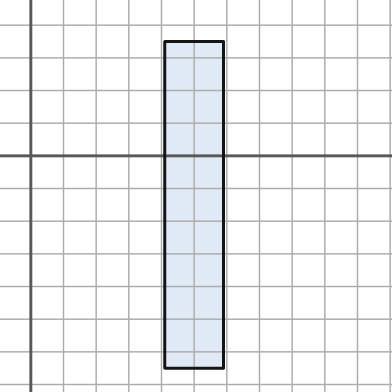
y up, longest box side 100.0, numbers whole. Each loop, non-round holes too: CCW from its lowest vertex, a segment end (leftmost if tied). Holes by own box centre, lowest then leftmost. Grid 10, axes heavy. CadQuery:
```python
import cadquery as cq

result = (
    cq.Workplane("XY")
    .moveTo(41.0, -65.0)
    .lineTo(59.0, -65.0)
    .lineTo(59.0, 35.0)
    .lineTo(41.0, 35.0)
    .close()
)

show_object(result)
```